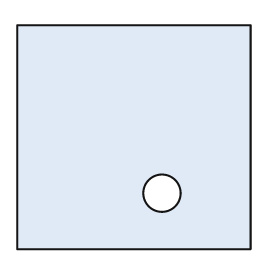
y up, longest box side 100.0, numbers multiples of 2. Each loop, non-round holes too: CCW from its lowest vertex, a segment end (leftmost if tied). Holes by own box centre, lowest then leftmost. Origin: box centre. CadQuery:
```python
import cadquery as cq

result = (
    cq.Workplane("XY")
    .moveTo(-50.0, -48.0)
    .lineTo(50.0, -48.0)
    .lineTo(50.0, 48.0)
    .lineTo(-50.0, 48.0)
    .close()
    .moveTo(12.0, -24.0)
    .circle(8.0)
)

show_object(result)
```